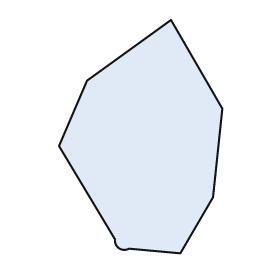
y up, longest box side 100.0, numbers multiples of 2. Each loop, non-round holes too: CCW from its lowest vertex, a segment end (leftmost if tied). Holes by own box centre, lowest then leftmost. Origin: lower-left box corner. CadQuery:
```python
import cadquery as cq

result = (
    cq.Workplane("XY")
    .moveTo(52.0, 0.0)
    .lineTo(66.0, 24.0)
    .lineTo(70.0, 62.0)
    .lineTo(48.0, 100.0)
    .lineTo(12.0, 74.0)
    .lineTo(0.0, 46.0)
    .lineTo(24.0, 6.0)
    .threePointArc((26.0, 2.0), (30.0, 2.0))
    .close()
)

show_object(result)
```